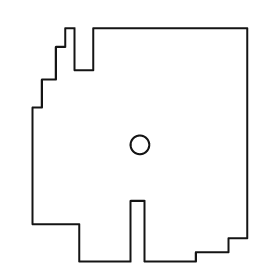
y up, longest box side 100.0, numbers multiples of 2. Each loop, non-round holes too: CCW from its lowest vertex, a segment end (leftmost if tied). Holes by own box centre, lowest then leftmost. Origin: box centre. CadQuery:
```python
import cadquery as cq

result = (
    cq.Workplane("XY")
    .moveTo(-26.0, -50.0)
    .lineTo(-4.0, -50.0)
    .lineTo(-4.0, -24.0)
    .lineTo(2.0, -24.0)
    .lineTo(2.0, -50.0)
    .lineTo(24.0, -50.0)
    .lineTo(24.0, -46.0)
    .lineTo(38.0, -46.0)
    .lineTo(38.0, -40.0)
    .lineTo(46.0, -40.0)
    .lineTo(46.0, 50.0)
    .lineTo(-20.0, 50.0)
    .lineTo(-20.0, 32.0)
    .lineTo(-28.0, 32.0)
    .lineTo(-28.0, 50.0)
    .lineTo(-32.0, 50.0)
    .lineTo(-32.0, 42.0)
    .lineTo(-36.0, 42.0)
    .lineTo(-36.0, 28.0)
    .lineTo(-42.0, 28.0)
    .lineTo(-42.0, 16.0)
    .lineTo(-46.0, 16.0)
    .lineTo(-46.0, -34.0)
    .lineTo(-26.0, -34.0)
    .close()
    .moveTo(0.0, 0.0)
    .circle(4.0)
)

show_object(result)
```